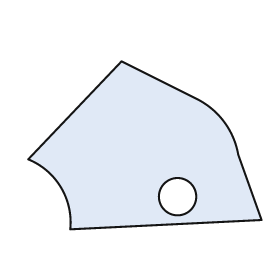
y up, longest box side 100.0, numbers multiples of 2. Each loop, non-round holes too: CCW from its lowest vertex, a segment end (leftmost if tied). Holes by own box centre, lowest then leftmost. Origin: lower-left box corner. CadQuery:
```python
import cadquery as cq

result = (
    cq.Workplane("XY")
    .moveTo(18.0, 0.0)
    .lineTo(100.0, 4.0)
    .lineTo(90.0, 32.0)
    .threePointArc((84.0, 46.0), (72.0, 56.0))
    .lineTo(40.0, 72.0)
    .lineTo(0.0, 30.0)
    .threePointArc((14.0, 18.0), (18.0, 0.0))
    .close()
    .moveTo(64.0, 14.0)
    .circle(8.0)
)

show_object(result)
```